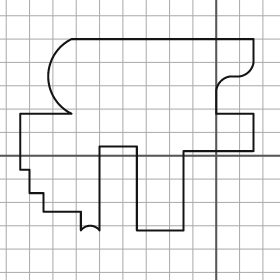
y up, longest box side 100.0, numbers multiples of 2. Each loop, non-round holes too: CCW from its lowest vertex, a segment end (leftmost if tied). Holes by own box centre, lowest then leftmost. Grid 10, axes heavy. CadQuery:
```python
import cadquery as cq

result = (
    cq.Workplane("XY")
    .moveTo(-58.0, -32.0)
    .threePointArc((-54.0, -30.0), (-50.0, -32.0))
    .lineTo(-50.0, 4.0)
    .lineTo(-34.0, 4.0)
    .lineTo(-34.0, -32.0)
    .lineTo(-14.0, -32.0)
    .lineTo(-14.0, 2.0)
    .lineTo(16.0, 2.0)
    .lineTo(16.0, 18.0)
    .lineTo(0.0, 18.0)
    .lineTo(0.0, 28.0)
    .threePointArc((2.0, 32.0), (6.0, 34.0))
    .lineTo(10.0, 34.0)
    .threePointArc((14.0, 36.0), (16.0, 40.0))
    .lineTo(16.0, 50.0)
    .lineTo(-62.0, 50.0)
    .threePointArc((-72.0, 34.0), (-62.0, 18.0))
    .lineTo(-84.0, 18.0)
    .lineTo(-84.0, -6.0)
    .lineTo(-80.0, -6.0)
    .lineTo(-80.0, -16.0)
    .lineTo(-74.0, -16.0)
    .lineTo(-74.0, -24.0)
    .lineTo(-58.0, -24.0)
    .close()
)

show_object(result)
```